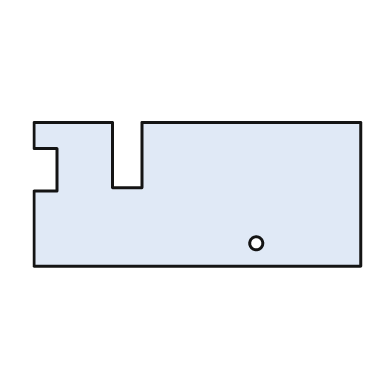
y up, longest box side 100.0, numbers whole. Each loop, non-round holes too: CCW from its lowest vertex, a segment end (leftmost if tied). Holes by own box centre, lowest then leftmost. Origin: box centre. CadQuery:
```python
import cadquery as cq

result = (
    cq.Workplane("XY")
    .moveTo(-50.0, -22.0)
    .lineTo(50.0, -22.0)
    .lineTo(50.0, 22.0)
    .lineTo(-17.0, 22.0)
    .lineTo(-17.0, 2.0)
    .lineTo(-26.0, 2.0)
    .lineTo(-26.0, 22.0)
    .lineTo(-50.0, 22.0)
    .lineTo(-50.0, 14.0)
    .lineTo(-43.0, 14.0)
    .lineTo(-43.0, 1.0)
    .lineTo(-50.0, 1.0)
    .close()
    .moveTo(18.0, -15.0)
    .circle(2.0)
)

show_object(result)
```